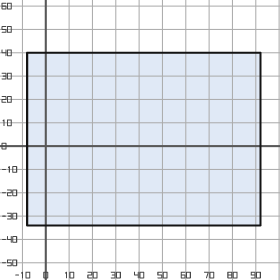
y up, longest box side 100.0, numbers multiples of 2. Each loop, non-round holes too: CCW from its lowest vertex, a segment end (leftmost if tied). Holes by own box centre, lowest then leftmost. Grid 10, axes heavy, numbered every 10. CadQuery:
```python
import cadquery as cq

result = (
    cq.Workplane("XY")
    .moveTo(-8.0, -34.0)
    .lineTo(92.0, -34.0)
    .lineTo(92.0, 40.0)
    .lineTo(-8.0, 40.0)
    .close()
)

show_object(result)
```